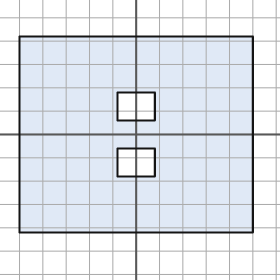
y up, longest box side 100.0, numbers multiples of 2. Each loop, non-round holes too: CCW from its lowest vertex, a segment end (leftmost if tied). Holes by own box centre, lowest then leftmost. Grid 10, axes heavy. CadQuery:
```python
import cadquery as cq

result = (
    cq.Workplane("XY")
    .moveTo(-50.0, -42.0)
    .lineTo(50.0, -42.0)
    .lineTo(50.0, 42.0)
    .lineTo(-50.0, 42.0)
    .close()
    .moveTo(-8.0, -18.0)
    .lineTo(8.0, -18.0)
    .lineTo(8.0, -6.0)
    .lineTo(-8.0, -6.0)
    .close()
    .moveTo(-8.0, 6.0)
    .lineTo(8.0, 6.0)
    .lineTo(8.0, 18.0)
    .lineTo(-8.0, 18.0)
    .close()
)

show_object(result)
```